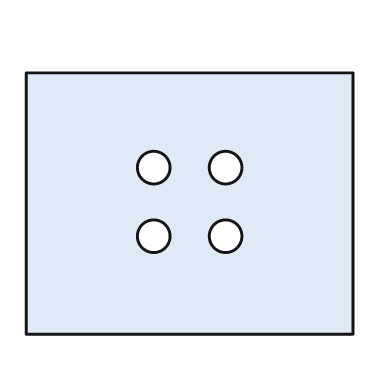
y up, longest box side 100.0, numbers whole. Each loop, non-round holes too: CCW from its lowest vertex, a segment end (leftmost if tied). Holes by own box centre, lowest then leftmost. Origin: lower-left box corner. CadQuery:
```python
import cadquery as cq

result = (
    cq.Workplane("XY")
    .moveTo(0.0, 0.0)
    .lineTo(100.0, 0.0)
    .lineTo(100.0, 80.0)
    .lineTo(0.0, 80.0)
    .close()
    .moveTo(39.0, 30.0)
    .circle(5.0)
    .moveTo(61.0, 30.0)
    .circle(5.0)
    .moveTo(39.0, 51.0)
    .circle(5.0)
    .moveTo(61.0, 51.0)
    .circle(5.0)
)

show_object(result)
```